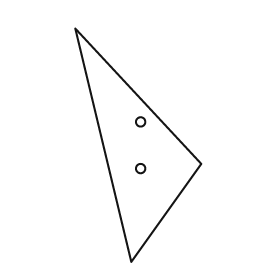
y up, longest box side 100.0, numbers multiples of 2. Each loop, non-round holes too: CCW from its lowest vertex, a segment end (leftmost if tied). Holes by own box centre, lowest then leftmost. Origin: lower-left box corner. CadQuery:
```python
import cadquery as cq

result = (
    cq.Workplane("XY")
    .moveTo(24.0, 0.0)
    .lineTo(54.0, 42.0)
    .lineTo(0.0, 100.0)
    .close()
    .moveTo(28.0, 40.0)
    .circle(2.0)
    .moveTo(28.0, 60.0)
    .circle(2.0)
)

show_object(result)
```